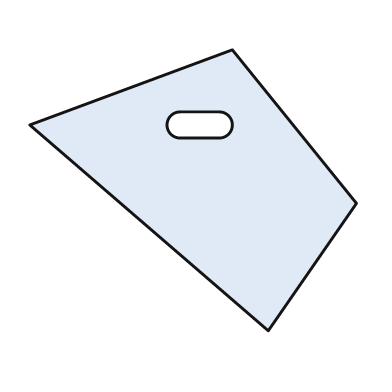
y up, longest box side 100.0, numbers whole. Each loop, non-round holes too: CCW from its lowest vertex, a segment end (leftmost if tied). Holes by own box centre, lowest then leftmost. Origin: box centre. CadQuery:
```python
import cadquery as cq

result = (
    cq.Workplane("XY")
    .moveTo(23.0, -43.0)
    .lineTo(50.0, -4.0)
    .lineTo(12.0, 43.0)
    .lineTo(-50.0, 20.0)
    .close()
    .moveTo(-4.0, 16.0)
    .lineTo(8.0, 16.0)
    .threePointArc((12.0, 20.0), (8.0, 24.0))
    .lineTo(-4.0, 24.0)
    .threePointArc((-8.0, 20.0), (-4.0, 16.0))
    .close()
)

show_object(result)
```